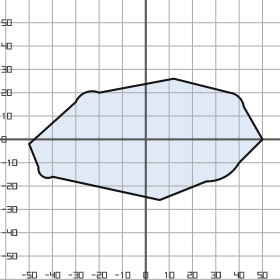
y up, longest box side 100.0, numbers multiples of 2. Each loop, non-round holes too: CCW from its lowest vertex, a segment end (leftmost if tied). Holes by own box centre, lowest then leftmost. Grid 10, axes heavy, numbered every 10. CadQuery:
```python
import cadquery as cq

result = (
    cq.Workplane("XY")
    .moveTo(6.0, -26.0)
    .lineTo(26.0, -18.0)
    .threePointArc((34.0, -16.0), (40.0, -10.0))
    .lineTo(50.0, 0.0)
    .lineTo(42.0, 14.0)
    .threePointArc((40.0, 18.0), (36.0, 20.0))
    .lineTo(12.0, 26.0)
    .lineTo(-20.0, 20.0)
    .threePointArc((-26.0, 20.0), (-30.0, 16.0))
    .lineTo(-50.0, -2.0)
    .lineTo(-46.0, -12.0)
    .threePointArc((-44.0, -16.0), (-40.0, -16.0))
    .close()
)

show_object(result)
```